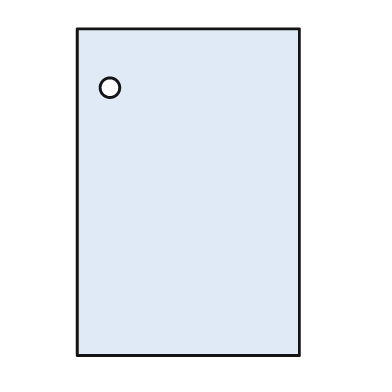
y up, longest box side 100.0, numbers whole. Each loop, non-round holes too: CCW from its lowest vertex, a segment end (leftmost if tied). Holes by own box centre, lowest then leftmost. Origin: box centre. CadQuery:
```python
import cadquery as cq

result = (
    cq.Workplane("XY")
    .moveTo(-34.0, -50.0)
    .lineTo(34.0, -50.0)
    .lineTo(34.0, 50.0)
    .lineTo(-34.0, 50.0)
    .close()
    .moveTo(-24.0, 32.0)
    .circle(3.0)
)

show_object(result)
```